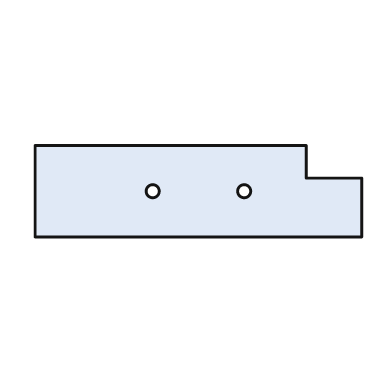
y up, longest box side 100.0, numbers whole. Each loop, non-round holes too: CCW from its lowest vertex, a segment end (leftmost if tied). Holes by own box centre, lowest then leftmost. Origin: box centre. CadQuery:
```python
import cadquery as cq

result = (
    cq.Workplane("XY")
    .moveTo(-50.0, -14.0)
    .lineTo(50.0, -14.0)
    .lineTo(50.0, 4.0)
    .lineTo(33.0, 4.0)
    .lineTo(33.0, 14.0)
    .lineTo(-50.0, 14.0)
    .close()
    .moveTo(-14.0, 0.0)
    .circle(2.0)
    .moveTo(14.0, 0.0)
    .circle(2.0)
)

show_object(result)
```